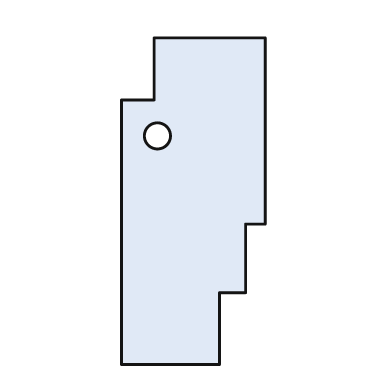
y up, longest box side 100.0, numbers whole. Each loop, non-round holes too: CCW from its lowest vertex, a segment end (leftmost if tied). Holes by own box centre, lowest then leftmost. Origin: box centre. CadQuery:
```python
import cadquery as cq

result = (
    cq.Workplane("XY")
    .moveTo(-22.0, -50.0)
    .lineTo(8.0, -50.0)
    .lineTo(8.0, -28.0)
    .lineTo(16.0, -28.0)
    .lineTo(16.0, -7.0)
    .lineTo(22.0, -7.0)
    .lineTo(22.0, 50.0)
    .lineTo(-12.0, 50.0)
    .lineTo(-12.0, 31.0)
    .lineTo(-22.0, 31.0)
    .close()
    .moveTo(-11.0, 20.0)
    .circle(4.0)
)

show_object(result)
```